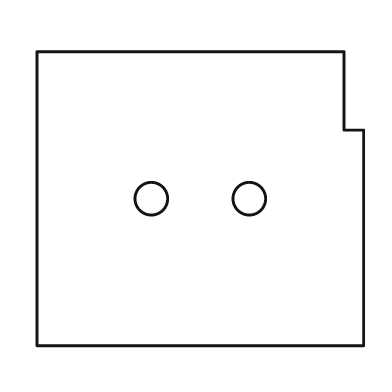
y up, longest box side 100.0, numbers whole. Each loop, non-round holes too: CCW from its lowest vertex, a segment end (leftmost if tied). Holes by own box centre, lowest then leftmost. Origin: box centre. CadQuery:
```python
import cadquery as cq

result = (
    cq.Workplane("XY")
    .moveTo(-50.0, -45.0)
    .lineTo(50.0, -45.0)
    .lineTo(50.0, 21.0)
    .lineTo(44.0, 21.0)
    .lineTo(44.0, 45.0)
    .lineTo(-50.0, 45.0)
    .close()
    .moveTo(-15.0, 0.0)
    .circle(5.0)
    .moveTo(15.0, 0.0)
    .circle(5.0)
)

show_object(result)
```